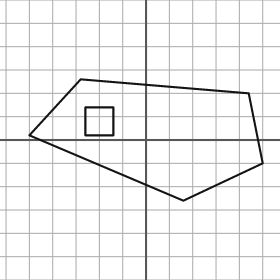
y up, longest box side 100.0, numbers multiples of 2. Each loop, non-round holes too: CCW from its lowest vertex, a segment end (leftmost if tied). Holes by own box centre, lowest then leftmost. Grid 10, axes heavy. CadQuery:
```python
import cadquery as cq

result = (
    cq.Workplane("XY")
    .moveTo(16.0, -26.0)
    .lineTo(50.0, -10.0)
    .lineTo(44.0, 20.0)
    .lineTo(-28.0, 26.0)
    .lineTo(-50.0, 2.0)
    .close()
    .moveTo(-26.0, 2.0)
    .lineTo(-14.0, 2.0)
    .lineTo(-14.0, 14.0)
    .lineTo(-26.0, 14.0)
    .close()
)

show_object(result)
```